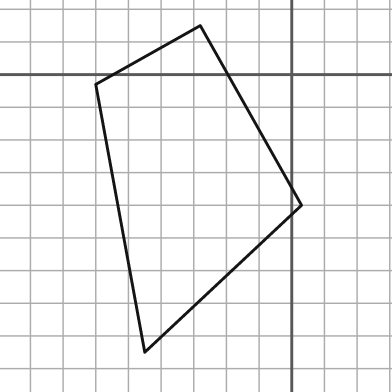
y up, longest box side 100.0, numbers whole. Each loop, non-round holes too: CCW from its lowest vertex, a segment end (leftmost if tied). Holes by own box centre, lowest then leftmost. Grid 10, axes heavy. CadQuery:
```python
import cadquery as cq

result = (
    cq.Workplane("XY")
    .moveTo(-45.0, -85.0)
    .lineTo(3.0, -40.0)
    .lineTo(-28.0, 15.0)
    .lineTo(-60.0, -3.0)
    .close()
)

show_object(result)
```